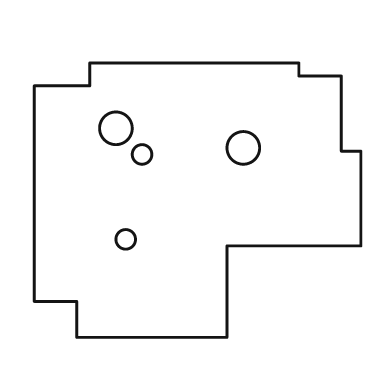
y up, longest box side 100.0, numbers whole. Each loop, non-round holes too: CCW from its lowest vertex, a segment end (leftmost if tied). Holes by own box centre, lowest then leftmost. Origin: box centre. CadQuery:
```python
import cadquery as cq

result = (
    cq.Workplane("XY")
    .moveTo(-37.0, -42.0)
    .lineTo(9.0, -42.0)
    .lineTo(9.0, -14.0)
    .lineTo(50.0, -14.0)
    .lineTo(50.0, 15.0)
    .lineTo(44.0, 15.0)
    .lineTo(44.0, 38.0)
    .lineTo(31.0, 38.0)
    .lineTo(31.0, 42.0)
    .lineTo(-33.0, 42.0)
    .lineTo(-33.0, 35.0)
    .lineTo(-50.0, 35.0)
    .lineTo(-50.0, -31.0)
    .lineTo(-37.0, -31.0)
    .close()
    .moveTo(-22.0, -12.0)
    .circle(3.0)
    .moveTo(-17.0, 14.0)
    .circle(3.0)
    .moveTo(14.0, 16.0)
    .circle(5.0)
    .moveTo(-25.0, 22.0)
    .circle(5.0)
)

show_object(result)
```